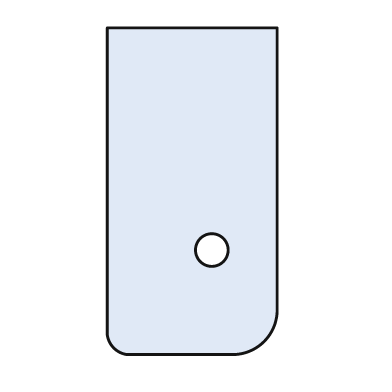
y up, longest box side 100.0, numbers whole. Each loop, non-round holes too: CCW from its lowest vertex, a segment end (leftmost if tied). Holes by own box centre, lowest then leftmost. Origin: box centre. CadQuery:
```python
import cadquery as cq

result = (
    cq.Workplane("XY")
    .moveTo(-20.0, -50.0)
    .lineTo(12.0, -50.0)
    .threePointArc((22.0, -46.0), (26.0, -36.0))
    .lineTo(26.0, 50.0)
    .lineTo(-26.0, 50.0)
    .lineTo(-26.0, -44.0)
    .threePointArc((-24.0, -48.0), (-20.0, -50.0))
    .close()
    .moveTo(6.0, -18.0)
    .circle(5.0)
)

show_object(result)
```